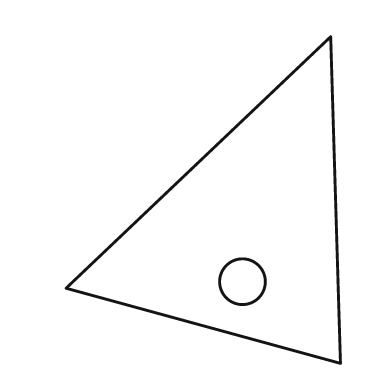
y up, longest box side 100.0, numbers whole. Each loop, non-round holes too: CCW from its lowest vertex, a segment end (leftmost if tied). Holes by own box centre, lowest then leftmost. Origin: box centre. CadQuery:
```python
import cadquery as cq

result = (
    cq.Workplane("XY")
    .moveTo(42.0, -50.0)
    .lineTo(39.0, 50.0)
    .lineTo(-42.0, -27.0)
    .close()
    .moveTo(12.0, -25.0)
    .circle(7.0)
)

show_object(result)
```